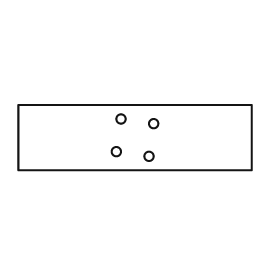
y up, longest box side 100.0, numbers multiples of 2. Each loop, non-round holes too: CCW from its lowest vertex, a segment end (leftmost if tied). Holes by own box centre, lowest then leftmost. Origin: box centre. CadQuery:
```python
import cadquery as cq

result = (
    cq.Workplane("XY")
    .moveTo(-50.0, -14.0)
    .lineTo(50.0, -14.0)
    .lineTo(50.0, 14.0)
    .lineTo(-50.0, 14.0)
    .close()
    .moveTo(6.0, -8.0)
    .circle(2.0)
    .moveTo(-8.0, -6.0)
    .circle(2.0)
    .moveTo(8.0, 6.0)
    .circle(2.0)
    .moveTo(-6.0, 8.0)
    .circle(2.0)
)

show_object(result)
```